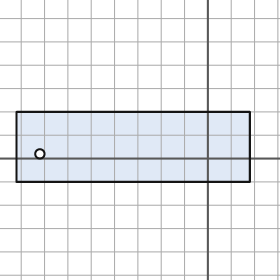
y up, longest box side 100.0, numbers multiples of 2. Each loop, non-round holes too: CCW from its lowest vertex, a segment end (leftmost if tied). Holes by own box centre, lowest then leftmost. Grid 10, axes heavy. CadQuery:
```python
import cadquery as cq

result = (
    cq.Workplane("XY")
    .moveTo(-82.0, -10.0)
    .lineTo(18.0, -10.0)
    .lineTo(18.0, 20.0)
    .lineTo(-82.0, 20.0)
    .close()
    .moveTo(-72.0, 2.0)
    .circle(2.0)
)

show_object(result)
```